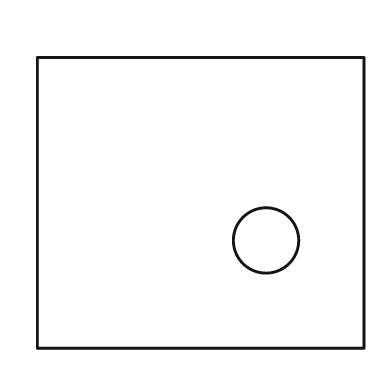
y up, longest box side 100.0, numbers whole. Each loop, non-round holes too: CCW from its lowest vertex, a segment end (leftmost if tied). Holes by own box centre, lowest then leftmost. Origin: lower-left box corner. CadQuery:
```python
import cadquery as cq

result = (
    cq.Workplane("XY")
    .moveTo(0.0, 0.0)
    .lineTo(100.0, 0.0)
    .lineTo(100.0, 89.0)
    .lineTo(0.0, 89.0)
    .close()
    .moveTo(70.0, 33.0)
    .circle(10.0)
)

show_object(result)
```